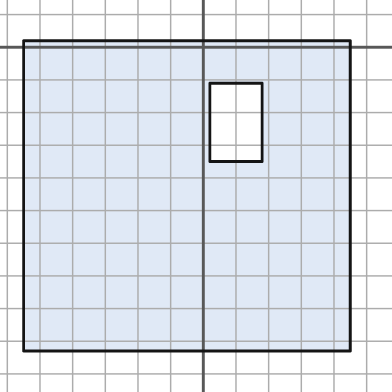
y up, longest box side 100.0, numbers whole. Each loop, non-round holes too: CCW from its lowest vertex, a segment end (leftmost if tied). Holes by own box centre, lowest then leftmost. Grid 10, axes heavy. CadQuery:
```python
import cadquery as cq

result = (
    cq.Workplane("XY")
    .moveTo(-55.0, -93.0)
    .lineTo(45.0, -93.0)
    .lineTo(45.0, 2.0)
    .lineTo(-55.0, 2.0)
    .close()
    .moveTo(2.0, -35.0)
    .lineTo(18.0, -35.0)
    .lineTo(18.0, -11.0)
    .lineTo(2.0, -11.0)
    .close()
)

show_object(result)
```